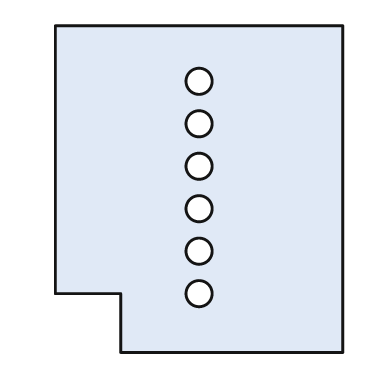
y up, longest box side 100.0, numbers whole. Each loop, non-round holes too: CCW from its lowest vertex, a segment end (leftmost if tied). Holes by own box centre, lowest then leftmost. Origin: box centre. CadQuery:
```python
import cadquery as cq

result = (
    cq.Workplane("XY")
    .moveTo(-24.0, -50.0)
    .lineTo(44.0, -50.0)
    .lineTo(44.0, 50.0)
    .lineTo(-44.0, 50.0)
    .lineTo(-44.0, -32.0)
    .lineTo(-24.0, -32.0)
    .close()
    .moveTo(0.0, -32.0)
    .circle(4.0)
    .moveTo(0.0, -19.0)
    .circle(4.0)
    .moveTo(0.0, -6.0)
    .circle(4.0)
    .moveTo(0.0, 7.0)
    .circle(4.0)
    .moveTo(0.0, 20.0)
    .circle(4.0)
    .moveTo(0.0, 33.0)
    .circle(4.0)
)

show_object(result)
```